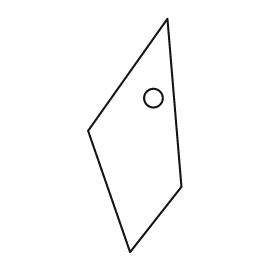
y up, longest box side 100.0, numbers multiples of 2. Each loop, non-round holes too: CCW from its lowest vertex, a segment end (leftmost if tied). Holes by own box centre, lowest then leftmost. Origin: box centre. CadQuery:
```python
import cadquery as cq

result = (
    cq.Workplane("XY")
    .moveTo(-2.0, -50.0)
    .lineTo(20.0, -22.0)
    .lineTo(14.0, 50.0)
    .lineTo(-20.0, 2.0)
    .close()
    .moveTo(8.0, 16.0)
    .circle(4.0)
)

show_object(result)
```